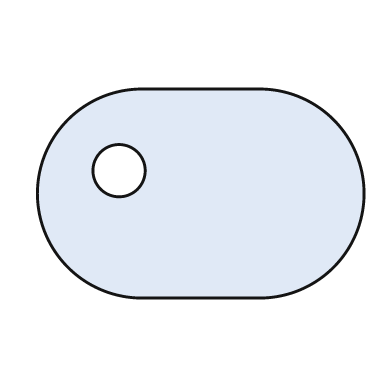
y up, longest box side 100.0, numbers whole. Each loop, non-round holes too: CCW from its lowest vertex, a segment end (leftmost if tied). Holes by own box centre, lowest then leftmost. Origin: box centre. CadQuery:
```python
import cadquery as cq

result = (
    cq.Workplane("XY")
    .moveTo(-18.0, -32.0)
    .lineTo(18.0, -32.0)
    .threePointArc((50.0, 0.0), (18.0, 32.0))
    .lineTo(-18.0, 32.0)
    .threePointArc((-50.0, 0.0), (-18.0, -32.0))
    .close()
    .moveTo(-25.0, 7.0)
    .circle(8.0)
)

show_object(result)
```